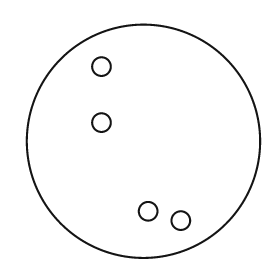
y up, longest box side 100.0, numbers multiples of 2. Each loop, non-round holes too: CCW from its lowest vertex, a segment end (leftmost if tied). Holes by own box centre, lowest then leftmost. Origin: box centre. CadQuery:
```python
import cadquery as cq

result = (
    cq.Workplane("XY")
    .moveTo(0.0, 0.0)
    .circle(50.0)
    .moveTo(16.0, -34.0)
    .circle(4.0)
    .moveTo(2.0, -30.0)
    .circle(4.0)
    .moveTo(-18.0, 8.0)
    .circle(4.0)
    .moveTo(-18.0, 32.0)
    .circle(4.0)
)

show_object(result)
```